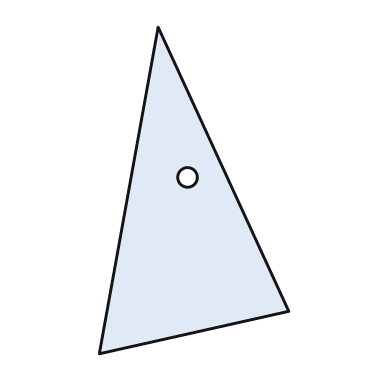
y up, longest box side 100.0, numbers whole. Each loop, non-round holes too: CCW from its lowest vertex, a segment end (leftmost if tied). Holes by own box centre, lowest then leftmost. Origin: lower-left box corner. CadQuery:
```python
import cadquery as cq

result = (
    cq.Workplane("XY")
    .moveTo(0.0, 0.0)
    .lineTo(58.0, 13.0)
    .lineTo(18.0, 100.0)
    .close()
    .moveTo(27.0, 54.0)
    .circle(3.0)
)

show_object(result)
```